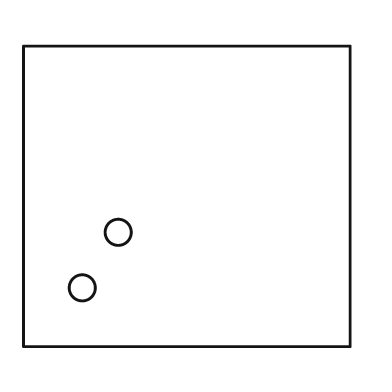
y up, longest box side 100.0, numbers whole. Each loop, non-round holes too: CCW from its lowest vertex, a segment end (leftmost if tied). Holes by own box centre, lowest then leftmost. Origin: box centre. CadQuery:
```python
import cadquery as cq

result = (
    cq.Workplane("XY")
    .moveTo(-50.0, -46.0)
    .lineTo(50.0, -46.0)
    .lineTo(50.0, 46.0)
    .lineTo(-50.0, 46.0)
    .close()
    .moveTo(-32.0, -28.0)
    .circle(4.0)
    .moveTo(-21.0, -11.0)
    .circle(4.0)
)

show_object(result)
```